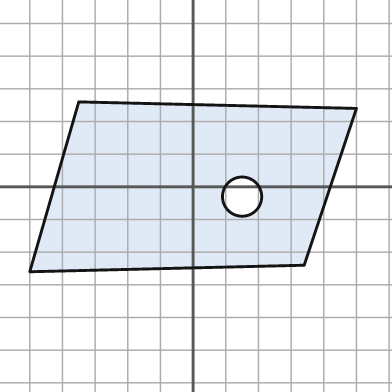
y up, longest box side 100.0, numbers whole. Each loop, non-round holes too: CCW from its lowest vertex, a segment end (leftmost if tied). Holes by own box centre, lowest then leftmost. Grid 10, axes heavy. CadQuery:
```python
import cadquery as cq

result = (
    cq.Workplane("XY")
    .moveTo(-50.0, -26.0)
    .lineTo(34.0, -24.0)
    .lineTo(50.0, 24.0)
    .lineTo(-35.0, 26.0)
    .close()
    .moveTo(15.0, -3.0)
    .circle(6.0)
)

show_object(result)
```